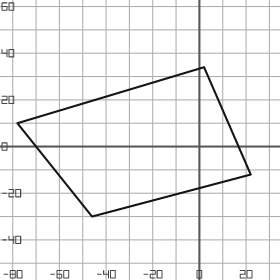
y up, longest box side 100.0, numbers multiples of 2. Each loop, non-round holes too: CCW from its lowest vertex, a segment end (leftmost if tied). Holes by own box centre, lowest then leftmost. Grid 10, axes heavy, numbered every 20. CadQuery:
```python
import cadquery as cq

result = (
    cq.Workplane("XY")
    .moveTo(-46.0, -30.0)
    .lineTo(22.0, -12.0)
    .lineTo(2.0, 34.0)
    .lineTo(-78.0, 10.0)
    .close()
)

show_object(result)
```